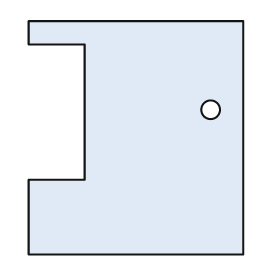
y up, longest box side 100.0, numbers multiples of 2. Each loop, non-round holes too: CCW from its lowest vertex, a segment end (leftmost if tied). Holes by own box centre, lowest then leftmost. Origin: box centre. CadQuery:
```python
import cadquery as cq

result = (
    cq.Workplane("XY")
    .moveTo(-46.0, -50.0)
    .lineTo(46.0, -50.0)
    .lineTo(46.0, 50.0)
    .lineTo(-46.0, 50.0)
    .lineTo(-46.0, 40.0)
    .lineTo(-22.0, 40.0)
    .lineTo(-22.0, -18.0)
    .lineTo(-46.0, -18.0)
    .close()
    .moveTo(32.0, 12.0)
    .circle(4.0)
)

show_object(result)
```